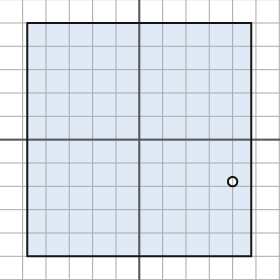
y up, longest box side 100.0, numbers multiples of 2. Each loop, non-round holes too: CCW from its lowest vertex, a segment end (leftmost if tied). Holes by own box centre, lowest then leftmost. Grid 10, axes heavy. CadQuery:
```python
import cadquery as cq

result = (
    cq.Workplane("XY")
    .moveTo(-48.0, -50.0)
    .lineTo(48.0, -50.0)
    .lineTo(48.0, 50.0)
    .lineTo(-48.0, 50.0)
    .close()
    .moveTo(40.0, -18.0)
    .circle(2.0)
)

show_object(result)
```